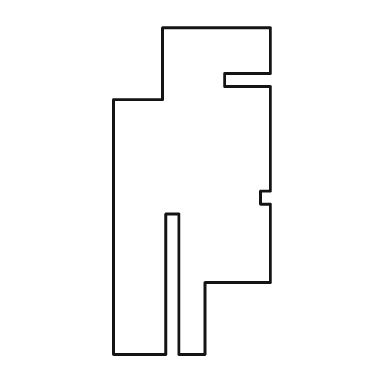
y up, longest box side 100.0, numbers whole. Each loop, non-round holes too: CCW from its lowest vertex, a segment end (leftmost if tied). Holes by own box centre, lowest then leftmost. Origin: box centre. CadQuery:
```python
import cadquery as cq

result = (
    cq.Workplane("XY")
    .moveTo(-24.0, -50.0)
    .lineTo(-8.0, -50.0)
    .lineTo(-8.0, -7.0)
    .lineTo(-4.0, -7.0)
    .lineTo(-4.0, -50.0)
    .lineTo(4.0, -50.0)
    .lineTo(4.0, -28.0)
    .lineTo(24.0, -28.0)
    .lineTo(24.0, -4.0)
    .lineTo(21.0, -4.0)
    .lineTo(21.0, 0.0)
    .lineTo(24.0, 0.0)
    .lineTo(24.0, 32.0)
    .lineTo(10.0, 32.0)
    .lineTo(10.0, 36.0)
    .lineTo(24.0, 36.0)
    .lineTo(24.0, 50.0)
    .lineTo(-9.0, 50.0)
    .lineTo(-9.0, 28.0)
    .lineTo(-24.0, 28.0)
    .close()
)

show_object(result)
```